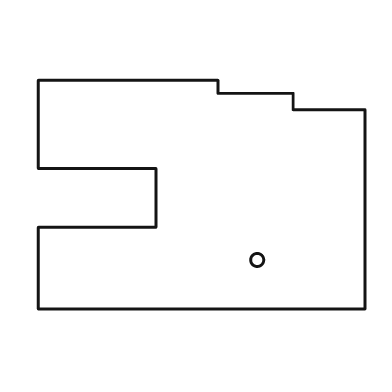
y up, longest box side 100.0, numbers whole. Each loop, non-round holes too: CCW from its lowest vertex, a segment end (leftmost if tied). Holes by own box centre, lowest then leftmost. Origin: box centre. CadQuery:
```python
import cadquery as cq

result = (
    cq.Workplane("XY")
    .moveTo(-50.0, -35.0)
    .lineTo(50.0, -35.0)
    .lineTo(50.0, 26.0)
    .lineTo(28.0, 26.0)
    .lineTo(28.0, 31.0)
    .lineTo(5.0, 31.0)
    .lineTo(5.0, 35.0)
    .lineTo(-50.0, 35.0)
    .lineTo(-50.0, 8.0)
    .lineTo(-14.0, 8.0)
    .lineTo(-14.0, -10.0)
    .lineTo(-50.0, -10.0)
    .close()
    .moveTo(17.0, -20.0)
    .circle(2.0)
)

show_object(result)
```